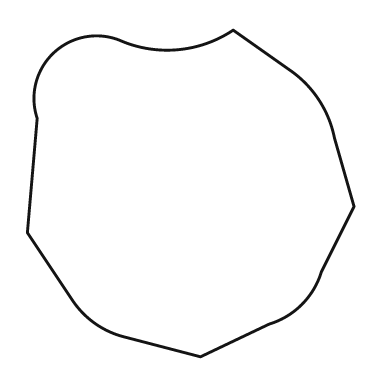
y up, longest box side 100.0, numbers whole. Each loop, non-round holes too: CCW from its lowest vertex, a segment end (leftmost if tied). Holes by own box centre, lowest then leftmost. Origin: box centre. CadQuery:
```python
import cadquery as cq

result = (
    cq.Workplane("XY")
    .moveTo(3.0, -50.0)
    .lineTo(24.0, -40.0)
    .threePointArc((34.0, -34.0), (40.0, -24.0))
    .lineTo(50.0, -4.0)
    .lineTo(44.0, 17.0)
    .threePointArc((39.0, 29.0), (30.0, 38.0))
    .lineTo(13.0, 50.0)
    .threePointArc((-4.0, 44.0), (-22.0, 47.0))
    .threePointArc((-42.0, 43.0), (-47.0, 23.0))
    .lineTo(-50.0, -12.0)
    .lineTo(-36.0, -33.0)
    .threePointArc((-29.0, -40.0), (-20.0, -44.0))
    .close()
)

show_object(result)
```